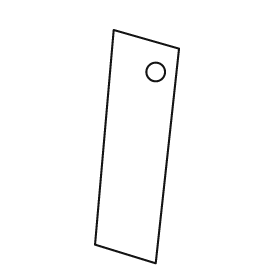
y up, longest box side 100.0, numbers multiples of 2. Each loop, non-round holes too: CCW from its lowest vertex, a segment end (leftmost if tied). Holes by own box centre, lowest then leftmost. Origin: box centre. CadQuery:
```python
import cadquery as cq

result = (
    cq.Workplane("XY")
    .moveTo(8.0, -50.0)
    .lineTo(18.0, 42.0)
    .lineTo(-10.0, 50.0)
    .lineTo(-18.0, -42.0)
    .close()
    .moveTo(8.0, 32.0)
    .circle(4.0)
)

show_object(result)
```